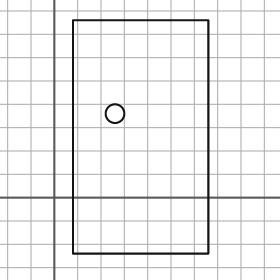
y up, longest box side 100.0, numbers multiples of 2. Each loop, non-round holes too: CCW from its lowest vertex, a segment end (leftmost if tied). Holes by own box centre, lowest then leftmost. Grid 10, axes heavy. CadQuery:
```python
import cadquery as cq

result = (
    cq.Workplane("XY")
    .moveTo(8.0, -24.0)
    .lineTo(66.0, -24.0)
    .lineTo(66.0, 76.0)
    .lineTo(8.0, 76.0)
    .close()
    .moveTo(26.0, 36.0)
    .circle(4.0)
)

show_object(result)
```